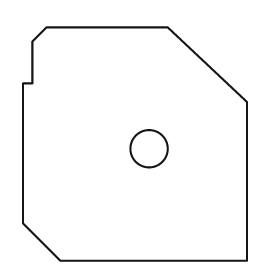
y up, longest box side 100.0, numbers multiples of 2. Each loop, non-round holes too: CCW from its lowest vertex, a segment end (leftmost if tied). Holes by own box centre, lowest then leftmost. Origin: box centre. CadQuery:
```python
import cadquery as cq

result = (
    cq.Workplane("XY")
    .moveTo(-32.0, -50.0)
    .lineTo(48.0, -50.0)
    .lineTo(48.0, 18.0)
    .lineTo(14.0, 50.0)
    .lineTo(-38.0, 50.0)
    .lineTo(-44.0, 44.0)
    .lineTo(-44.0, 26.0)
    .lineTo(-48.0, 26.0)
    .lineTo(-48.0, -34.0)
    .close()
    .moveTo(6.0, -2.0)
    .circle(8.0)
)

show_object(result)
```